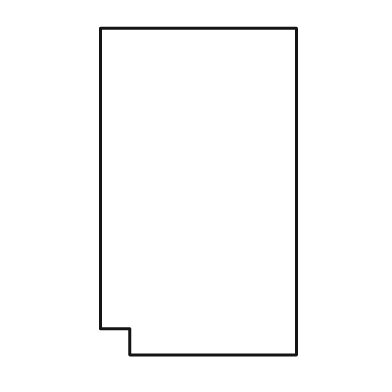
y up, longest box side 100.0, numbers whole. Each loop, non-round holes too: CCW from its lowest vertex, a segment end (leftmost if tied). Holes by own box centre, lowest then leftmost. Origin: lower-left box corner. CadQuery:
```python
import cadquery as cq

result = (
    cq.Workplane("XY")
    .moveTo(9.0, 0.0)
    .lineTo(60.0, 0.0)
    .lineTo(60.0, 100.0)
    .lineTo(0.0, 100.0)
    .lineTo(0.0, 8.0)
    .lineTo(9.0, 8.0)
    .close()
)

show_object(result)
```